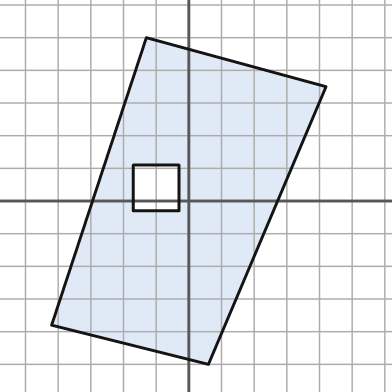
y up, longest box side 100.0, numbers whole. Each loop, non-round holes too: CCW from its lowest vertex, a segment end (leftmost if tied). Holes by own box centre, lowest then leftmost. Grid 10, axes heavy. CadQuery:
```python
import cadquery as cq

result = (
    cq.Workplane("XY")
    .moveTo(6.0, -50.0)
    .lineTo(42.0, 35.0)
    .lineTo(-13.0, 50.0)
    .lineTo(-42.0, -38.0)
    .close()
    .moveTo(-17.0, -3.0)
    .lineTo(-3.0, -3.0)
    .lineTo(-3.0, 11.0)
    .lineTo(-17.0, 11.0)
    .close()
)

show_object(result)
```